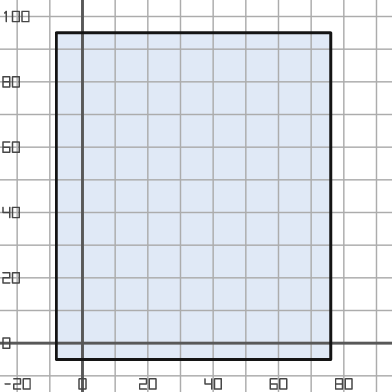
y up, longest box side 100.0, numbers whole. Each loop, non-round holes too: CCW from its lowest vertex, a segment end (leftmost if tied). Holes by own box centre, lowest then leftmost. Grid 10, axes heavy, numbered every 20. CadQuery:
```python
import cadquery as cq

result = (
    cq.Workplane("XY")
    .moveTo(-8.0, -5.0)
    .lineTo(76.0, -5.0)
    .lineTo(76.0, 95.0)
    .lineTo(-8.0, 95.0)
    .close()
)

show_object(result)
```